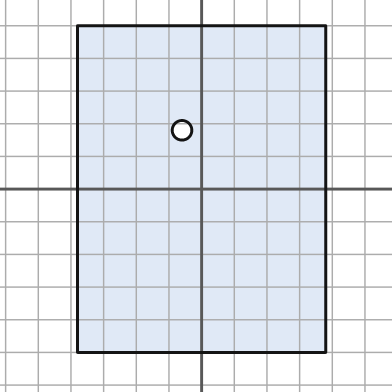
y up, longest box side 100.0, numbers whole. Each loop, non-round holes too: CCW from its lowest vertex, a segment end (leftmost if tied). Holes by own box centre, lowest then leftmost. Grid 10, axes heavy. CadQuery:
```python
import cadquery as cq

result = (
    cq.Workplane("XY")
    .moveTo(-38.0, -50.0)
    .lineTo(38.0, -50.0)
    .lineTo(38.0, 50.0)
    .lineTo(-38.0, 50.0)
    .close()
    .moveTo(-6.0, 18.0)
    .circle(3.0)
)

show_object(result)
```